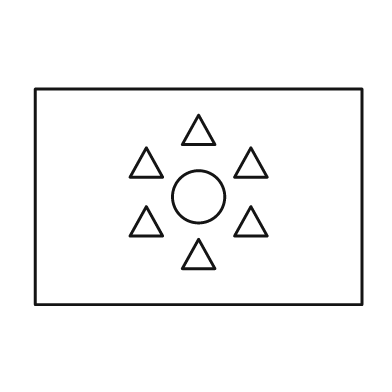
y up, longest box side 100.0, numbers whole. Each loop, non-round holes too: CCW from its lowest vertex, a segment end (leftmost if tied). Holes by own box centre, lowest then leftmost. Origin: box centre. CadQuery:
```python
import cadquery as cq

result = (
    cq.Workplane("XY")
    .moveTo(-50.0, -33.0)
    .lineTo(50.0, -33.0)
    .lineTo(50.0, 33.0)
    .lineTo(-50.0, 33.0)
    .close()
    .moveTo(-5.0, -22.0)
    .lineTo(5.0, -22.0)
    .lineTo(0.0, -13.0)
    .close()
    .moveTo(-21.0, -12.0)
    .lineTo(-11.0, -12.0)
    .lineTo(-16.0, -3.0)
    .close()
    .moveTo(11.0, -12.0)
    .lineTo(21.0, -12.0)
    .lineTo(16.0, -3.0)
    .close()
    .moveTo(0.0, 0.0)
    .circle(8.0)
    .moveTo(-21.0, 6.0)
    .lineTo(-11.0, 6.0)
    .lineTo(-16.0, 15.0)
    .close()
    .moveTo(11.0, 6.0)
    .lineTo(21.0, 6.0)
    .lineTo(16.0, 15.0)
    .close()
    .moveTo(-5.0, 16.0)
    .lineTo(5.0, 16.0)
    .lineTo(0.0, 25.0)
    .close()
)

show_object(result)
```